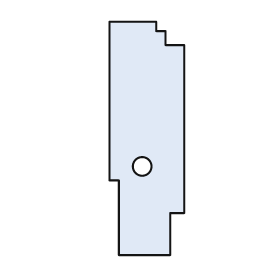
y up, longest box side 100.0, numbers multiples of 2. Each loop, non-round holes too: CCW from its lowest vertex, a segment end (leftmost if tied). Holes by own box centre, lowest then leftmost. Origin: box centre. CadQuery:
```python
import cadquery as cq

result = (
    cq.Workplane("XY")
    .moveTo(-12.0, -50.0)
    .lineTo(10.0, -50.0)
    .lineTo(10.0, -32.0)
    .lineTo(16.0, -32.0)
    .lineTo(16.0, 40.0)
    .lineTo(8.0, 40.0)
    .lineTo(8.0, 46.0)
    .lineTo(4.0, 46.0)
    .lineTo(4.0, 50.0)
    .lineTo(-16.0, 50.0)
    .lineTo(-16.0, -18.0)
    .lineTo(-12.0, -18.0)
    .close()
    .moveTo(-2.0, -12.0)
    .circle(4.0)
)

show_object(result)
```